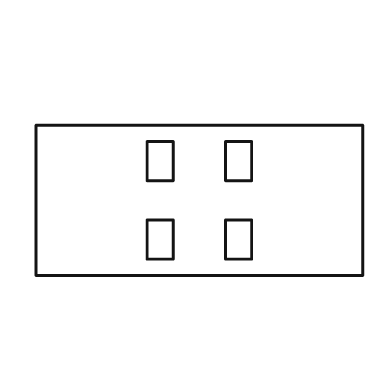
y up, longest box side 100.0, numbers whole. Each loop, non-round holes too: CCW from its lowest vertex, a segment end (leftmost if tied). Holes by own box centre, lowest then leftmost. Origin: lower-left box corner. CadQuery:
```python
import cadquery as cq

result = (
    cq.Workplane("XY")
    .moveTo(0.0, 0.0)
    .lineTo(100.0, 0.0)
    .lineTo(100.0, 46.0)
    .lineTo(0.0, 46.0)
    .close()
    .moveTo(34.0, 5.0)
    .lineTo(42.0, 5.0)
    .lineTo(42.0, 17.0)
    .lineTo(34.0, 17.0)
    .close()
    .moveTo(58.0, 5.0)
    .lineTo(66.0, 5.0)
    .lineTo(66.0, 17.0)
    .lineTo(58.0, 17.0)
    .close()
    .moveTo(34.0, 29.0)
    .lineTo(42.0, 29.0)
    .lineTo(42.0, 41.0)
    .lineTo(34.0, 41.0)
    .close()
    .moveTo(58.0, 29.0)
    .lineTo(66.0, 29.0)
    .lineTo(66.0, 41.0)
    .lineTo(58.0, 41.0)
    .close()
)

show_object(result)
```